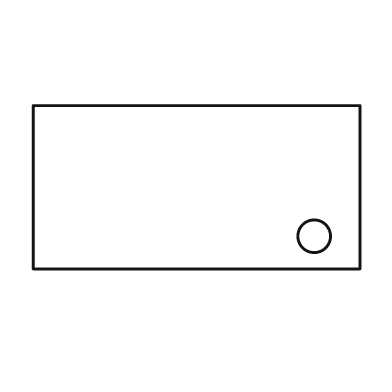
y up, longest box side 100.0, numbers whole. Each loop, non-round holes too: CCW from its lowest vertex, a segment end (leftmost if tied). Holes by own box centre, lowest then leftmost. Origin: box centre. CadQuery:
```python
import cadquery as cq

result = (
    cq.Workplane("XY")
    .moveTo(-50.0, -25.0)
    .lineTo(50.0, -25.0)
    .lineTo(50.0, 25.0)
    .lineTo(-50.0, 25.0)
    .close()
    .moveTo(36.0, -15.0)
    .circle(5.0)
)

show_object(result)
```